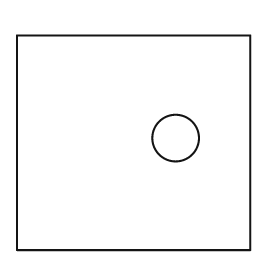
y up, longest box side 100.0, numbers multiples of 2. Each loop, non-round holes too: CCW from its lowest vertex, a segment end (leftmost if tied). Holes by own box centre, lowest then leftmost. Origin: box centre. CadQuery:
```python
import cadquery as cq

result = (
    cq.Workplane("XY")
    .moveTo(-50.0, -46.0)
    .lineTo(50.0, -46.0)
    .lineTo(50.0, 46.0)
    .lineTo(-50.0, 46.0)
    .close()
    .moveTo(18.0, 2.0)
    .circle(10.0)
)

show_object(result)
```